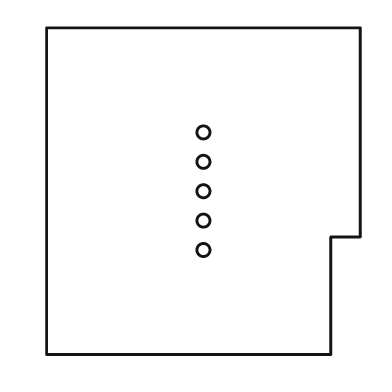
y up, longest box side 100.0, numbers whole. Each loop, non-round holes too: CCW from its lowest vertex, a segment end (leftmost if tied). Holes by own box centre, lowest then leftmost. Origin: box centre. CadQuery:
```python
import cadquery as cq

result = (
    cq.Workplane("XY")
    .moveTo(-48.0, -50.0)
    .lineTo(39.0, -50.0)
    .lineTo(39.0, -14.0)
    .lineTo(48.0, -14.0)
    .lineTo(48.0, 50.0)
    .lineTo(-48.0, 50.0)
    .close()
    .moveTo(0.0, -18.0)
    .circle(2.0)
    .moveTo(0.0, -9.0)
    .circle(2.0)
    .moveTo(0.0, 0.0)
    .circle(2.0)
    .moveTo(0.0, 9.0)
    .circle(2.0)
    .moveTo(0.0, 18.0)
    .circle(2.0)
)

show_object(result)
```